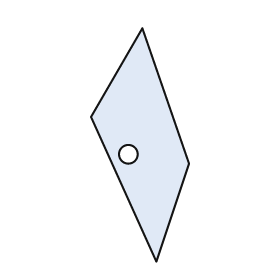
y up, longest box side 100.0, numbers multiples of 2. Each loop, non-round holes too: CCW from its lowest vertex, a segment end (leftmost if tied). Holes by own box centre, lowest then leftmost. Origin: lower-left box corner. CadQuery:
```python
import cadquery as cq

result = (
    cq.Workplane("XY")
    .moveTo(28.0, 0.0)
    .lineTo(42.0, 42.0)
    .lineTo(22.0, 100.0)
    .lineTo(0.0, 62.0)
    .close()
    .moveTo(16.0, 46.0)
    .circle(4.0)
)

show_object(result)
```